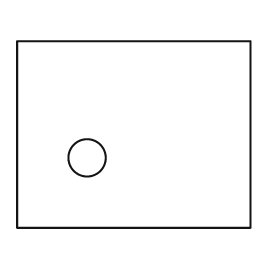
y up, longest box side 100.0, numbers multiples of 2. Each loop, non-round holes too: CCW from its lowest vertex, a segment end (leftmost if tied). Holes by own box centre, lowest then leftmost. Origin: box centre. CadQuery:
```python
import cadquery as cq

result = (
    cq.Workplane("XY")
    .moveTo(-50.0, -40.0)
    .lineTo(50.0, -40.0)
    .lineTo(50.0, 40.0)
    .lineTo(-50.0, 40.0)
    .close()
    .moveTo(-20.0, -10.0)
    .circle(8.0)
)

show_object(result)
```